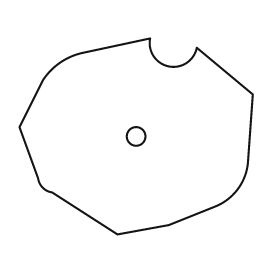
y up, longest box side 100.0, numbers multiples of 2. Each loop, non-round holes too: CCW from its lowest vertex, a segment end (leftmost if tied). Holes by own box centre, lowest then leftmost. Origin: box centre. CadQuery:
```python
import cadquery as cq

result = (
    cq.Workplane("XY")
    .moveTo(-8.0, -42.0)
    .lineTo(14.0, -38.0)
    .lineTo(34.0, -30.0)
    .threePointArc((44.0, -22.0), (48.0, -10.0))
    .lineTo(50.0, 18.0)
    .lineTo(26.0, 38.0)
    .threePointArc((14.0, 30.0), (6.0, 42.0))
    .lineTo(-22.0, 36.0)
    .threePointArc((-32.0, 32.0), (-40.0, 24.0))
    .lineTo(-50.0, 4.0)
    .lineTo(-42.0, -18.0)
    .threePointArc((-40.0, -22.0), (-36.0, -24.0))
    .close()
    .moveTo(0.0, 0.0)
    .circle(4.0)
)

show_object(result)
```